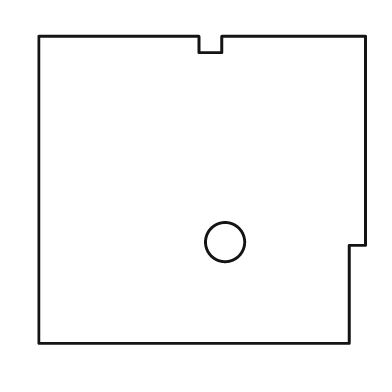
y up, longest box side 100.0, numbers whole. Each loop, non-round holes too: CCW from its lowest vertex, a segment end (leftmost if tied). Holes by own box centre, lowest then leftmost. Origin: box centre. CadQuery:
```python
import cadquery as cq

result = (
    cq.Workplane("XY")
    .moveTo(-50.0, -47.0)
    .lineTo(45.0, -47.0)
    .lineTo(45.0, -17.0)
    .lineTo(50.0, -17.0)
    .lineTo(50.0, 47.0)
    .lineTo(6.0, 47.0)
    .lineTo(6.0, 42.0)
    .lineTo(-1.0, 42.0)
    .lineTo(-1.0, 47.0)
    .lineTo(-50.0, 47.0)
    .close()
    .moveTo(7.0, -16.0)
    .circle(6.0)
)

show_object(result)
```